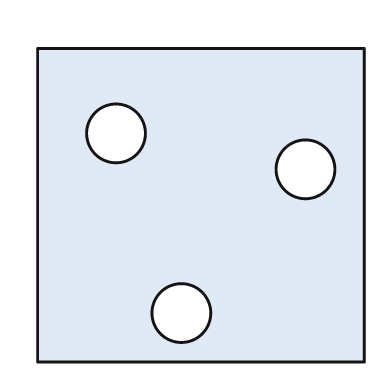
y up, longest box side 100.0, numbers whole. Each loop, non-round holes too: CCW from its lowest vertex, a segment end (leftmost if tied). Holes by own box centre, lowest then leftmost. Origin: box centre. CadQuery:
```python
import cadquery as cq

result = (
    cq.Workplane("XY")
    .moveTo(-50.0, -48.0)
    .lineTo(50.0, -48.0)
    .lineTo(50.0, 48.0)
    .lineTo(-50.0, 48.0)
    .close()
    .moveTo(-6.0, -33.0)
    .circle(9.0)
    .moveTo(32.0, 11.0)
    .circle(9.0)
    .moveTo(-26.0, 22.0)
    .circle(9.0)
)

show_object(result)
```